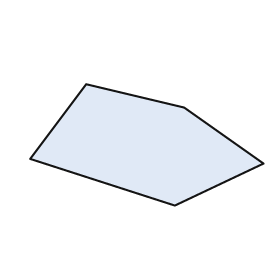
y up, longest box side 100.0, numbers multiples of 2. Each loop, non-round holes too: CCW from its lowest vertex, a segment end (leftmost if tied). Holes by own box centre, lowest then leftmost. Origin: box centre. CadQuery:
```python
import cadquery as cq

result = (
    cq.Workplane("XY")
    .moveTo(12.0, -26.0)
    .lineTo(50.0, -8.0)
    .lineTo(16.0, 16.0)
    .lineTo(-26.0, 26.0)
    .lineTo(-50.0, -6.0)
    .close()
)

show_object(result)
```